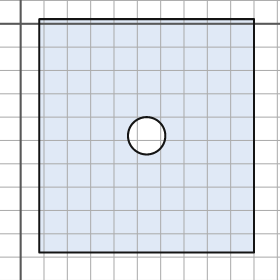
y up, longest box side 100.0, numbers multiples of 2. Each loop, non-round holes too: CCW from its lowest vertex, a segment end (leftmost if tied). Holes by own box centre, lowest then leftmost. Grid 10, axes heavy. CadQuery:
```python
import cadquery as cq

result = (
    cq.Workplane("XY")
    .moveTo(8.0, -98.0)
    .lineTo(100.0, -98.0)
    .lineTo(100.0, 2.0)
    .lineTo(8.0, 2.0)
    .close()
    .moveTo(54.0, -48.0)
    .circle(8.0)
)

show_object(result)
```